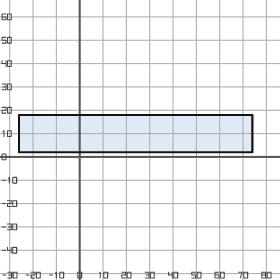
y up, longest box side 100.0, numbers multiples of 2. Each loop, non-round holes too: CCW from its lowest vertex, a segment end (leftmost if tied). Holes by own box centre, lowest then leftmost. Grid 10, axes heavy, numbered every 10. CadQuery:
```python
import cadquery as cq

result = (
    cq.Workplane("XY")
    .moveTo(-26.0, 2.0)
    .lineTo(74.0, 2.0)
    .lineTo(74.0, 18.0)
    .lineTo(-26.0, 18.0)
    .close()
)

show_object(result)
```